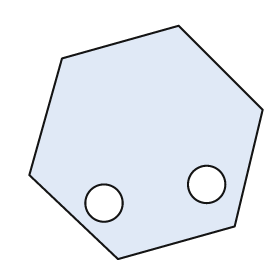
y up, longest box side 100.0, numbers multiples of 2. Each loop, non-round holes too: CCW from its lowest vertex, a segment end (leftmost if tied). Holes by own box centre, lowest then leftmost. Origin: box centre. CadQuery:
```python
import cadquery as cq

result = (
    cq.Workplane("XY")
    .moveTo(-12.0, -50.0)
    .lineTo(38.0, -36.0)
    .lineTo(50.0, 14.0)
    .lineTo(14.0, 50.0)
    .lineTo(-36.0, 36.0)
    .lineTo(-50.0, -14.0)
    .close()
    .moveTo(-18.0, -26.0)
    .circle(8.0)
    .moveTo(26.0, -18.0)
    .circle(8.0)
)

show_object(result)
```